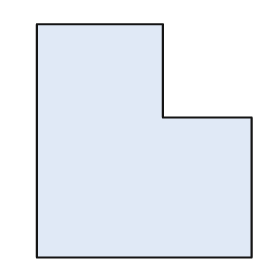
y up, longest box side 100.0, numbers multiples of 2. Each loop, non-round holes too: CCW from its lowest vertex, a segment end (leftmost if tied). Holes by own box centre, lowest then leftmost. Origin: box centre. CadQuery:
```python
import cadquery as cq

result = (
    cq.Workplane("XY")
    .moveTo(-46.0, -50.0)
    .lineTo(46.0, -50.0)
    .lineTo(46.0, 10.0)
    .lineTo(8.0, 10.0)
    .lineTo(8.0, 50.0)
    .lineTo(-46.0, 50.0)
    .close()
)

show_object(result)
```